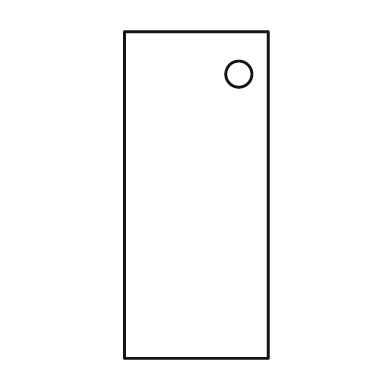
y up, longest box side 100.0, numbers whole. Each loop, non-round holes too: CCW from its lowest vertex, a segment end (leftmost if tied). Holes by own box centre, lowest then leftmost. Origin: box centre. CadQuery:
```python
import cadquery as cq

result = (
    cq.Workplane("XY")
    .moveTo(-22.0, -50.0)
    .lineTo(22.0, -50.0)
    .lineTo(22.0, 50.0)
    .lineTo(-22.0, 50.0)
    .close()
    .moveTo(13.0, 37.0)
    .circle(4.0)
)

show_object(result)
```